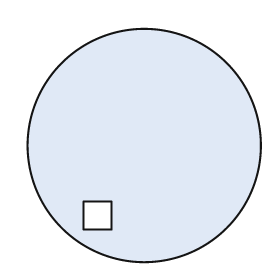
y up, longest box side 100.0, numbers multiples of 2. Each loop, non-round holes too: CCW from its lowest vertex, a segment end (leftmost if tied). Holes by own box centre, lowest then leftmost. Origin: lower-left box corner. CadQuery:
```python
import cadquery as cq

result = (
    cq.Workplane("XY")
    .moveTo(50.0, 50.0)
    .circle(50.0)
    .moveTo(24.0, 14.0)
    .lineTo(36.0, 14.0)
    .lineTo(36.0, 26.0)
    .lineTo(24.0, 26.0)
    .close()
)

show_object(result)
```